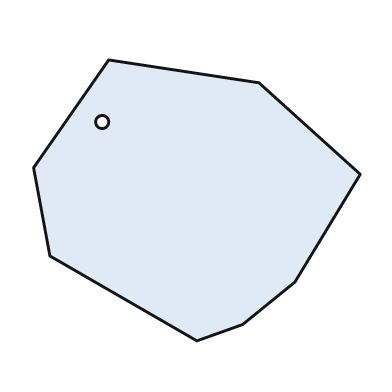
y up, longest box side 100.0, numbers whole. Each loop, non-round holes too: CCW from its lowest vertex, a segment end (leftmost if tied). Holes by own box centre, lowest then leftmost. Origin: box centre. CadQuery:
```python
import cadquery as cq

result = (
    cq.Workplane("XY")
    .moveTo(0.0, -43.0)
    .lineTo(14.0, -38.0)
    .lineTo(30.0, -25.0)
    .lineTo(50.0, 8.0)
    .lineTo(19.0, 36.0)
    .lineTo(-27.0, 43.0)
    .lineTo(-50.0, 10.0)
    .lineTo(-45.0, -17.0)
    .close()
    .moveTo(-29.0, 24.0)
    .circle(2.0)
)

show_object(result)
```